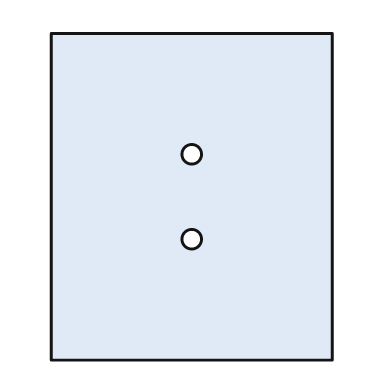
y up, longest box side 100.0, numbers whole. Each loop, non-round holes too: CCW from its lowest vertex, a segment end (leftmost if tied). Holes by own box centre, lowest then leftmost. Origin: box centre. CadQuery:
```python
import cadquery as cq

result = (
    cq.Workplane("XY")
    .moveTo(-43.0, -50.0)
    .lineTo(43.0, -50.0)
    .lineTo(43.0, 50.0)
    .lineTo(-43.0, 50.0)
    .close()
    .moveTo(0.0, -13.0)
    .circle(3.0)
    .moveTo(0.0, 13.0)
    .circle(3.0)
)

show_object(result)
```